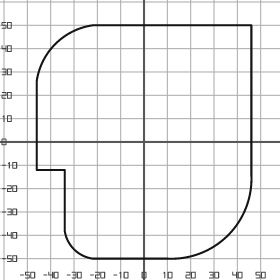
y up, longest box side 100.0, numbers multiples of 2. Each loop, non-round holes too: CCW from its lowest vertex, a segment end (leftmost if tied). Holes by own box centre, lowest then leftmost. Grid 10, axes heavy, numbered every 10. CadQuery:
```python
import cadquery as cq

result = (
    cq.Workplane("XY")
    .moveTo(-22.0, -50.0)
    .lineTo(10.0, -50.0)
    .threePointArc((36.0, -40.0), (46.0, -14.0))
    .lineTo(46.0, 50.0)
    .lineTo(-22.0, 50.0)
    .threePointArc((-38.0, 42.0), (-46.0, 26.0))
    .lineTo(-46.0, -12.0)
    .lineTo(-34.0, -12.0)
    .lineTo(-34.0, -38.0)
    .threePointArc((-30.0, -46.0), (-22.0, -50.0))
    .close()
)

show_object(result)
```